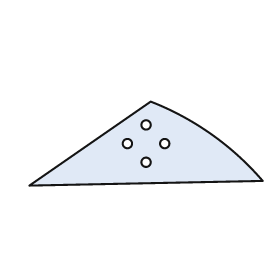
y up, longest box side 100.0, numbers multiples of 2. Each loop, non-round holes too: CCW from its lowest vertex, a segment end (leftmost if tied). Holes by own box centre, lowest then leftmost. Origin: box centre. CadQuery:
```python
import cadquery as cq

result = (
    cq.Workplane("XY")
    .moveTo(-50.0, -18.0)
    .lineTo(50.0, -16.0)
    .threePointArc((28.0, 4.0), (2.0, 18.0))
    .close()
    .moveTo(0.0, -8.0)
    .circle(2.0)
    .moveTo(-8.0, 0.0)
    .circle(2.0)
    .moveTo(8.0, 0.0)
    .circle(2.0)
    .moveTo(0.0, 8.0)
    .circle(2.0)
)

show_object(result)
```